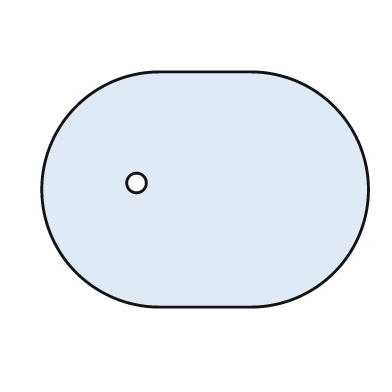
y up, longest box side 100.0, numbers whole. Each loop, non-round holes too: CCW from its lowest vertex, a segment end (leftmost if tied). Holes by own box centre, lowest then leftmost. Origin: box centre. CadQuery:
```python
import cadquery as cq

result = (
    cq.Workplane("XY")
    .moveTo(-14.0, -36.0)
    .lineTo(14.0, -36.0)
    .threePointArc((50.0, 0.0), (14.0, 36.0))
    .lineTo(-14.0, 36.0)
    .threePointArc((-50.0, 0.0), (-14.0, -36.0))
    .close()
    .moveTo(-21.0, 2.0)
    .circle(3.0)
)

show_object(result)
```